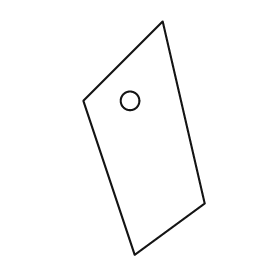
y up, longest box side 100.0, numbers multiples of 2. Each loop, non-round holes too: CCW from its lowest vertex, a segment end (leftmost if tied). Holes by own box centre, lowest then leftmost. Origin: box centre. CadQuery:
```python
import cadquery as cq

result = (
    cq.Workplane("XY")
    .moveTo(-4.0, -50.0)
    .lineTo(26.0, -28.0)
    .lineTo(8.0, 50.0)
    .lineTo(-26.0, 16.0)
    .close()
    .moveTo(-6.0, 16.0)
    .circle(4.0)
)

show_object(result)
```